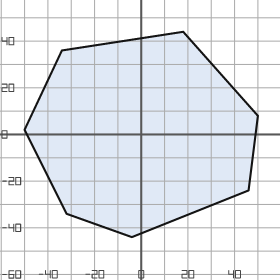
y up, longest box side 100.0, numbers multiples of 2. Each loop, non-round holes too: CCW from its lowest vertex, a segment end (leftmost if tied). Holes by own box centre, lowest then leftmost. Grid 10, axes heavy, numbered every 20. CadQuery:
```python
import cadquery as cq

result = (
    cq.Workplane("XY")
    .moveTo(-4.0, -44.0)
    .lineTo(46.0, -24.0)
    .lineTo(50.0, 8.0)
    .lineTo(18.0, 44.0)
    .lineTo(-34.0, 36.0)
    .lineTo(-50.0, 2.0)
    .lineTo(-32.0, -34.0)
    .close()
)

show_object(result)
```